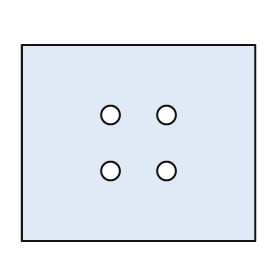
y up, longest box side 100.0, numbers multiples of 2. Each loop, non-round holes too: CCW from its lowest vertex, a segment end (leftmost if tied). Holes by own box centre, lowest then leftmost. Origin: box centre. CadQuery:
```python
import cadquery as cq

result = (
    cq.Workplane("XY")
    .moveTo(-50.0, -42.0)
    .lineTo(50.0, -42.0)
    .lineTo(50.0, 42.0)
    .lineTo(-50.0, 42.0)
    .close()
    .moveTo(-12.0, -12.0)
    .circle(4.0)
    .moveTo(12.0, -12.0)
    .circle(4.0)
    .moveTo(-12.0, 12.0)
    .circle(4.0)
    .moveTo(12.0, 12.0)
    .circle(4.0)
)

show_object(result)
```